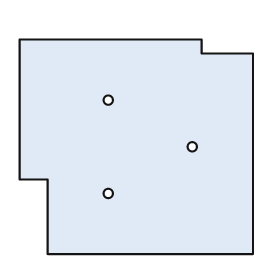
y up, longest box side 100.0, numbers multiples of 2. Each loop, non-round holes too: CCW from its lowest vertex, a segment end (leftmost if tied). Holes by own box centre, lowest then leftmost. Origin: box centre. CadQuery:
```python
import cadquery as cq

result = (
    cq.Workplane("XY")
    .moveTo(-38.0, -46.0)
    .lineTo(50.0, -46.0)
    .lineTo(50.0, 40.0)
    .lineTo(28.0, 40.0)
    .lineTo(28.0, 46.0)
    .lineTo(-50.0, 46.0)
    .lineTo(-50.0, -14.0)
    .lineTo(-38.0, -14.0)
    .close()
    .moveTo(-12.0, -20.0)
    .circle(2.0)
    .moveTo(24.0, 0.0)
    .circle(2.0)
    .moveTo(-12.0, 20.0)
    .circle(2.0)
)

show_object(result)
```